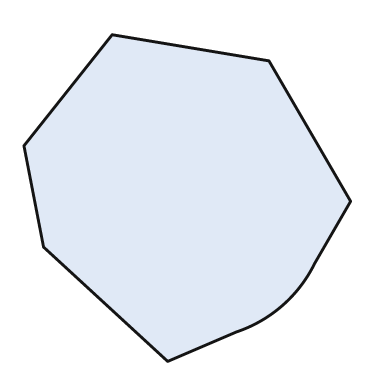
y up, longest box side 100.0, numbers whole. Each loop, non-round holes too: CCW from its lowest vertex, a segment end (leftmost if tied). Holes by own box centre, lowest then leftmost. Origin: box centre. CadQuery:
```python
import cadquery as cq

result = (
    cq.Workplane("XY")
    .moveTo(-6.0, -50.0)
    .lineTo(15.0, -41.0)
    .threePointArc((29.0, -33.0), (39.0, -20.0))
    .lineTo(50.0, -1.0)
    .lineTo(25.0, 42.0)
    .lineTo(-23.0, 50.0)
    .lineTo(-50.0, 16.0)
    .lineTo(-44.0, -15.0)
    .close()
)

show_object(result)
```